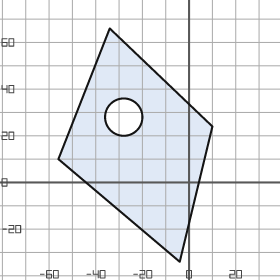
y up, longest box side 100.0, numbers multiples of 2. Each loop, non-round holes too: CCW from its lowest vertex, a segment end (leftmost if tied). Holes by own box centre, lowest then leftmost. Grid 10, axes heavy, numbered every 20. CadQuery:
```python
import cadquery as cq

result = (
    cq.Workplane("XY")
    .moveTo(-4.0, -34.0)
    .lineTo(10.0, 24.0)
    .lineTo(-34.0, 66.0)
    .lineTo(-56.0, 10.0)
    .close()
    .moveTo(-28.0, 28.0)
    .circle(8.0)
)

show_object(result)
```